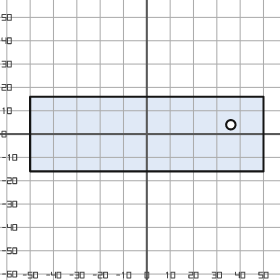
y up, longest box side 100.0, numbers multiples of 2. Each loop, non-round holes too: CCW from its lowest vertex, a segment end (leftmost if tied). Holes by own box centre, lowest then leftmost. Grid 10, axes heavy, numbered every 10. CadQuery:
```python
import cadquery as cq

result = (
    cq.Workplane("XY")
    .moveTo(-50.0, -16.0)
    .lineTo(50.0, -16.0)
    .lineTo(50.0, 16.0)
    .lineTo(-50.0, 16.0)
    .close()
    .moveTo(36.0, 4.0)
    .circle(2.0)
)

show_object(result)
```